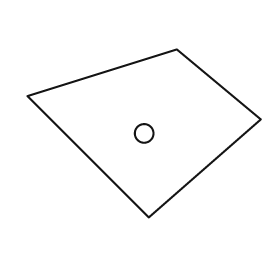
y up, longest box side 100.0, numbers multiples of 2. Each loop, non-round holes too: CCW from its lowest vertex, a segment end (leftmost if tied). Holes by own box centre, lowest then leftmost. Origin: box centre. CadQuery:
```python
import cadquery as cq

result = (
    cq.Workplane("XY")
    .moveTo(2.0, -36.0)
    .lineTo(50.0, 6.0)
    .lineTo(14.0, 36.0)
    .lineTo(-50.0, 16.0)
    .close()
    .moveTo(0.0, 0.0)
    .circle(4.0)
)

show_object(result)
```